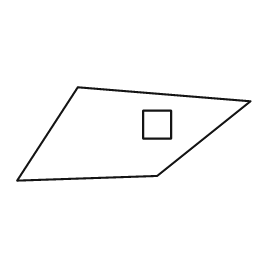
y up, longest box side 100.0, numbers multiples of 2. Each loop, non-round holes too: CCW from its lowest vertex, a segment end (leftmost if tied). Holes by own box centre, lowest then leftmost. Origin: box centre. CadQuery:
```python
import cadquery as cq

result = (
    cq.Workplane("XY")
    .moveTo(-50.0, -20.0)
    .lineTo(10.0, -18.0)
    .lineTo(50.0, 14.0)
    .lineTo(-24.0, 20.0)
    .close()
    .moveTo(4.0, -2.0)
    .lineTo(16.0, -2.0)
    .lineTo(16.0, 10.0)
    .lineTo(4.0, 10.0)
    .close()
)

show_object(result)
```